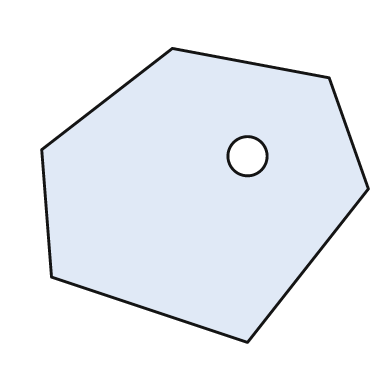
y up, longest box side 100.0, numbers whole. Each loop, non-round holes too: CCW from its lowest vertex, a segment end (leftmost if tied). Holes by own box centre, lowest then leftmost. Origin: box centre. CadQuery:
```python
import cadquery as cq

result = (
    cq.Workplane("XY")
    .moveTo(13.0, -45.0)
    .lineTo(50.0, 2.0)
    .lineTo(38.0, 36.0)
    .lineTo(-10.0, 45.0)
    .lineTo(-50.0, 14.0)
    .lineTo(-47.0, -25.0)
    .close()
    .moveTo(13.0, 12.0)
    .circle(6.0)
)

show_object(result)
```